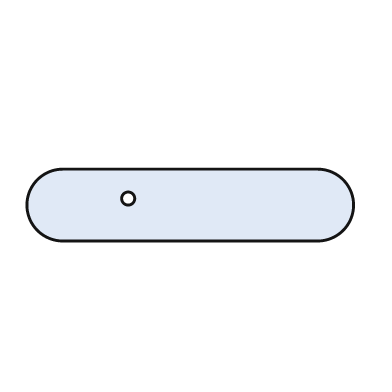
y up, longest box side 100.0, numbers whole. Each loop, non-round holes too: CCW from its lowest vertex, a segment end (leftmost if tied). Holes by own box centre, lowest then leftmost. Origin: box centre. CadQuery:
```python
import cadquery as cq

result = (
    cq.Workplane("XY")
    .moveTo(-39.0, -11.0)
    .lineTo(39.0, -11.0)
    .threePointArc((50.0, 0.0), (39.0, 11.0))
    .lineTo(-39.0, 11.0)
    .threePointArc((-50.0, 0.0), (-39.0, -11.0))
    .close()
    .moveTo(-19.0, 2.0)
    .circle(2.0)
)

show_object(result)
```